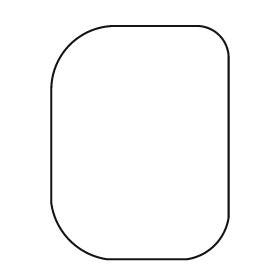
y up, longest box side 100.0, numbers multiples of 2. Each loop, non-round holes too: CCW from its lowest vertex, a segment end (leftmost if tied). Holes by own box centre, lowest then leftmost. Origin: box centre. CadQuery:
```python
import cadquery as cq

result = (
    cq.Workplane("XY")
    .moveTo(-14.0, -50.0)
    .lineTo(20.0, -50.0)
    .threePointArc((32.0, -44.0), (38.0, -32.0))
    .lineTo(38.0, 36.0)
    .threePointArc((34.0, 46.0), (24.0, 50.0))
    .lineTo(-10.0, 50.0)
    .threePointArc((-30.0, 42.0), (-38.0, 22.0))
    .lineTo(-38.0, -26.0)
    .threePointArc((-30.0, -42.0), (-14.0, -50.0))
    .close()
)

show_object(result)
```